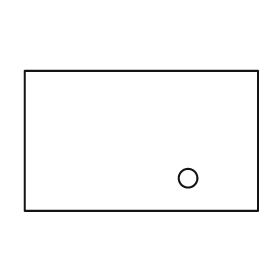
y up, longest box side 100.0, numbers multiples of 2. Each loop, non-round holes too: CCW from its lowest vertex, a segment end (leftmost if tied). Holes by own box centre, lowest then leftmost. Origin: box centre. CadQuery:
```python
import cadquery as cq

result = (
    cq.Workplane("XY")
    .moveTo(-50.0, -30.0)
    .lineTo(50.0, -30.0)
    .lineTo(50.0, 30.0)
    .lineTo(-50.0, 30.0)
    .close()
    .moveTo(20.0, -16.0)
    .circle(4.0)
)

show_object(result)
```